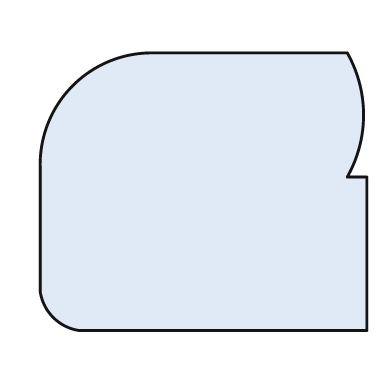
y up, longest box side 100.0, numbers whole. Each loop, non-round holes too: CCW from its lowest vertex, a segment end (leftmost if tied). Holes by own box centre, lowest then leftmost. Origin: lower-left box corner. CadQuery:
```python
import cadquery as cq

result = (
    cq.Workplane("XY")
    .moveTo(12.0, 0.0)
    .lineTo(100.0, 0.0)
    .lineTo(100.0, 47.0)
    .lineTo(94.0, 47.0)
    .threePointArc((99.0, 66.0), (94.0, 85.0))
    .lineTo(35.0, 85.0)
    .threePointArc((10.0, 75.0), (0.0, 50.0))
    .lineTo(0.0, 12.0)
    .threePointArc((4.0, 4.0), (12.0, 0.0))
    .close()
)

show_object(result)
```